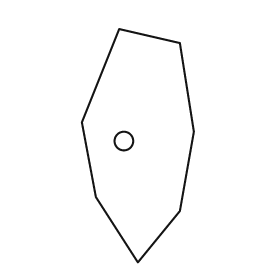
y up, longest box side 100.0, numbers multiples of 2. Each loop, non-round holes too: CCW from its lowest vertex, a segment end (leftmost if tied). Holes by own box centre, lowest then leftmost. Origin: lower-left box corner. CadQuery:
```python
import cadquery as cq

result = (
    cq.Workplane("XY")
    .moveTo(24.0, 0.0)
    .lineTo(42.0, 22.0)
    .lineTo(48.0, 56.0)
    .lineTo(42.0, 94.0)
    .lineTo(16.0, 100.0)
    .lineTo(0.0, 60.0)
    .lineTo(6.0, 28.0)
    .close()
    .moveTo(18.0, 52.0)
    .circle(4.0)
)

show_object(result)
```